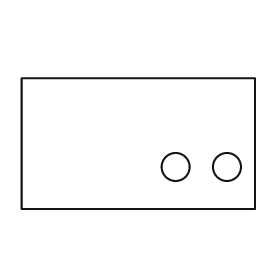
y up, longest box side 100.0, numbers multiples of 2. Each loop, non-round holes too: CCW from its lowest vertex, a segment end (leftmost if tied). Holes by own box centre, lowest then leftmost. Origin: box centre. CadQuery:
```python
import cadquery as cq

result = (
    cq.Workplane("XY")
    .moveTo(-50.0, -28.0)
    .lineTo(50.0, -28.0)
    .lineTo(50.0, 28.0)
    .lineTo(-50.0, 28.0)
    .close()
    .moveTo(16.0, -10.0)
    .circle(6.0)
    .moveTo(38.0, -10.0)
    .circle(6.0)
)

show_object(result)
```